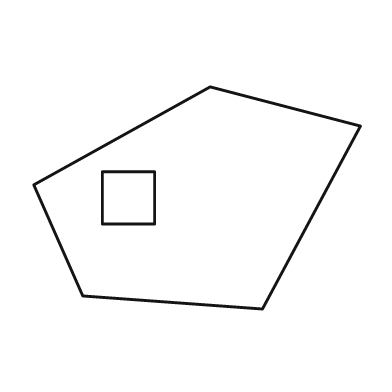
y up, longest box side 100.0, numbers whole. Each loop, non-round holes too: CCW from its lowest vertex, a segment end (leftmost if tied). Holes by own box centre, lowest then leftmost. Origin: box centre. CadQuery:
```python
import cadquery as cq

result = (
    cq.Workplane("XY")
    .moveTo(20.0, -34.0)
    .lineTo(50.0, 22.0)
    .lineTo(4.0, 34.0)
    .lineTo(-50.0, 4.0)
    .lineTo(-35.0, -30.0)
    .close()
    .moveTo(-29.0, -8.0)
    .lineTo(-13.0, -8.0)
    .lineTo(-13.0, 8.0)
    .lineTo(-29.0, 8.0)
    .close()
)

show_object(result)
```